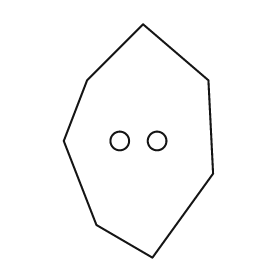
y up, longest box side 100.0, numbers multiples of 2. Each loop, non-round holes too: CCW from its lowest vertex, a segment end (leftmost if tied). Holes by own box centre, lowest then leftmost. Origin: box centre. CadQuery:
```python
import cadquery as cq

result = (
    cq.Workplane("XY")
    .moveTo(6.0, -50.0)
    .lineTo(32.0, -14.0)
    .lineTo(30.0, 26.0)
    .lineTo(2.0, 50.0)
    .lineTo(-22.0, 26.0)
    .lineTo(-32.0, 0.0)
    .lineTo(-18.0, -36.0)
    .close()
    .moveTo(-8.0, 0.0)
    .circle(4.0)
    .moveTo(8.0, 0.0)
    .circle(4.0)
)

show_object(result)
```